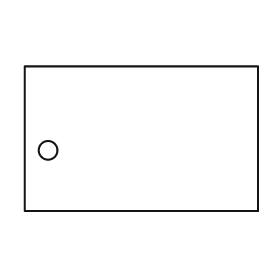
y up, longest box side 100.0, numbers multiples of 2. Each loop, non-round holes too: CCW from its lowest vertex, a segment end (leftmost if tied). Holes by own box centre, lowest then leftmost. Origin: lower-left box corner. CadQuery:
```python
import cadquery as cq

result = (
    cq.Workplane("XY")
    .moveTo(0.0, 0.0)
    .lineTo(100.0, 0.0)
    .lineTo(100.0, 62.0)
    .lineTo(0.0, 62.0)
    .close()
    .moveTo(10.0, 26.0)
    .circle(4.0)
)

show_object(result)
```